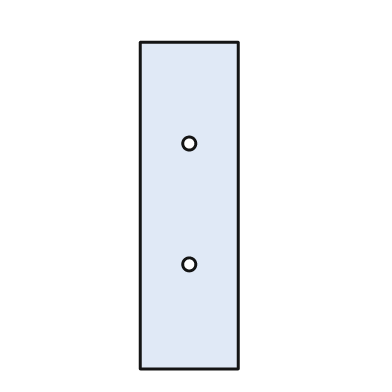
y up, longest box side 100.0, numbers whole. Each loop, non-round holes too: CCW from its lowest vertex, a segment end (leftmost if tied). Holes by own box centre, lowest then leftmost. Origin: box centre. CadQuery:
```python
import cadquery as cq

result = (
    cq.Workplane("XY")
    .moveTo(-15.0, -50.0)
    .lineTo(15.0, -50.0)
    .lineTo(15.0, 50.0)
    .lineTo(-15.0, 50.0)
    .close()
    .moveTo(0.0, -18.0)
    .circle(2.0)
    .moveTo(0.0, 19.0)
    .circle(2.0)
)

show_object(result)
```